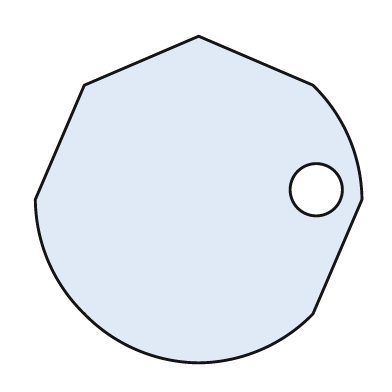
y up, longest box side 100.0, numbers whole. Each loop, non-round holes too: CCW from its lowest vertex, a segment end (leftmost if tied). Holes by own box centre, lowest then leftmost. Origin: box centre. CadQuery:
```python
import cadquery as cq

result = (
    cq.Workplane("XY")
    .moveTo(0.0, -50.0)
    .threePointArc((19.0, -46.0), (35.0, -35.0))
    .lineTo(50.0, 0.0)
    .threePointArc((46.0, 19.0), (35.0, 35.0))
    .lineTo(0.0, 50.0)
    .lineTo(-35.0, 35.0)
    .lineTo(-50.0, 0.0)
    .threePointArc((-46.0, -19.0), (-35.0, -35.0))
    .threePointArc((-19.0, -46.0), (0.0, -50.0))
    .close()
    .moveTo(36.0, 3.0)
    .circle(8.0)
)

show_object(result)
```